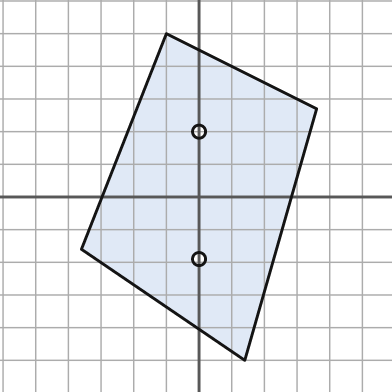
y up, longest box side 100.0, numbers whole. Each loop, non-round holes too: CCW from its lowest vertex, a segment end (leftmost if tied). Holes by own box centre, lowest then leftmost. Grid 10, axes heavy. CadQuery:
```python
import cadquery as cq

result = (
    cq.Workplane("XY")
    .moveTo(14.0, -50.0)
    .lineTo(36.0, 27.0)
    .lineTo(-10.0, 50.0)
    .lineTo(-36.0, -16.0)
    .close()
    .moveTo(0.0, -19.0)
    .circle(2.0)
    .moveTo(0.0, 20.0)
    .circle(2.0)
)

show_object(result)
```